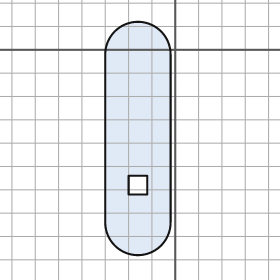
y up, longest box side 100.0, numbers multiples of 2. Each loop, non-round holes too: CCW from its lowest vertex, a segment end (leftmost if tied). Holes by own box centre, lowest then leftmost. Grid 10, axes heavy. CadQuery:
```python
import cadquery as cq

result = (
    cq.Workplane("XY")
    .moveTo(-30.0, -74.0)
    .threePointArc((-16.0, -88.0), (-2.0, -74.0))
    .lineTo(-2.0, -2.0)
    .threePointArc((-16.0, 12.0), (-30.0, -2.0))
    .close()
    .moveTo(-20.0, -62.0)
    .lineTo(-12.0, -62.0)
    .lineTo(-12.0, -54.0)
    .lineTo(-20.0, -54.0)
    .close()
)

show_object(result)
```